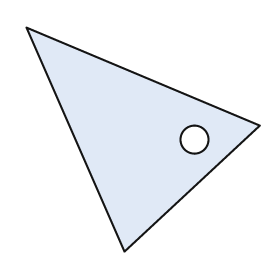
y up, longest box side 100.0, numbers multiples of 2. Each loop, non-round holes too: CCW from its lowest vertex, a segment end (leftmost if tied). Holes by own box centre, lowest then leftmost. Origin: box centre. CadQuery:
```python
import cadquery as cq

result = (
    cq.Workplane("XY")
    .moveTo(-8.0, -48.0)
    .lineTo(50.0, 6.0)
    .lineTo(-50.0, 48.0)
    .close()
    .moveTo(22.0, 0.0)
    .circle(6.0)
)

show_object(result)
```